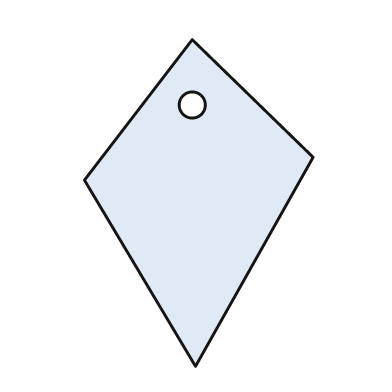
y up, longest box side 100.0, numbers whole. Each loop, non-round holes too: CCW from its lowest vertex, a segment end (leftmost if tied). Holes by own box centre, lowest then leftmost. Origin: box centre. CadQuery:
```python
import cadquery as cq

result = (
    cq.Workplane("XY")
    .moveTo(-1.0, -50.0)
    .lineTo(35.0, 14.0)
    .lineTo(-2.0, 50.0)
    .lineTo(-35.0, 7.0)
    .close()
    .moveTo(-2.0, 30.0)
    .circle(4.0)
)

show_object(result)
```